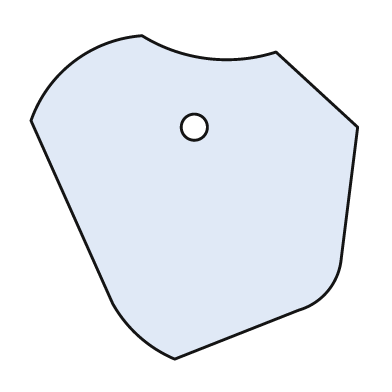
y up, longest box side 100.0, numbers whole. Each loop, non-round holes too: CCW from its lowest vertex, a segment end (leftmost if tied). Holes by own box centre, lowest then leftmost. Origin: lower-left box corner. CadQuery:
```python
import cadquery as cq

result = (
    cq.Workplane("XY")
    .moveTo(44.0, 0.0)
    .lineTo(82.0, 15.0)
    .threePointArc((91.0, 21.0), (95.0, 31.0))
    .lineTo(100.0, 71.0)
    .lineTo(75.0, 94.0)
    .threePointArc((54.0, 92.0), (34.0, 99.0))
    .threePointArc((13.0, 91.0), (0.0, 73.0))
    .lineTo(25.0, 17.0)
    .threePointArc((33.0, 7.0), (44.0, 0.0))
    .close()
    .moveTo(50.0, 71.0)
    .circle(4.0)
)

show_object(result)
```